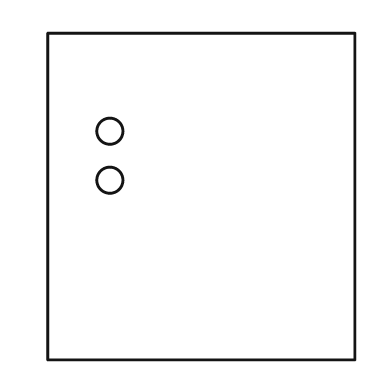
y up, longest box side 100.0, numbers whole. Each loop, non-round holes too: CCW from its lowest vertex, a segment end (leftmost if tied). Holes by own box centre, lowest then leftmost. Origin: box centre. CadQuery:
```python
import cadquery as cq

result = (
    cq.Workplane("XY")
    .moveTo(-47.0, -50.0)
    .lineTo(47.0, -50.0)
    .lineTo(47.0, 50.0)
    .lineTo(-47.0, 50.0)
    .close()
    .moveTo(-28.0, 5.0)
    .circle(4.0)
    .moveTo(-28.0, 20.0)
    .circle(4.0)
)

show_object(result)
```